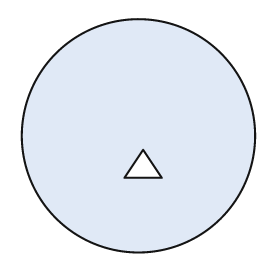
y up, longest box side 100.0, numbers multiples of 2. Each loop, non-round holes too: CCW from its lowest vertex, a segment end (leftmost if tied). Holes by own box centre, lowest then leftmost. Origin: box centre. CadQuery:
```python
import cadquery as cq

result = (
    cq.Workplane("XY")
    .moveTo(0.0, 0.0)
    .circle(50.0)
    .moveTo(-6.0, -18.0)
    .lineTo(10.0, -18.0)
    .lineTo(2.0, -6.0)
    .close()
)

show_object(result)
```